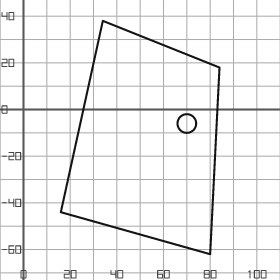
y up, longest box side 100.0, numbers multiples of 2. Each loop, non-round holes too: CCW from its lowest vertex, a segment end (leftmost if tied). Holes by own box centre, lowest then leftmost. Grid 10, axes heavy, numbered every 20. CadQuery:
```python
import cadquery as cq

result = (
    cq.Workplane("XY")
    .moveTo(80.0, -62.0)
    .lineTo(84.0, 18.0)
    .lineTo(34.0, 38.0)
    .lineTo(16.0, -44.0)
    .close()
    .moveTo(70.0, -6.0)
    .circle(4.0)
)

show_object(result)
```